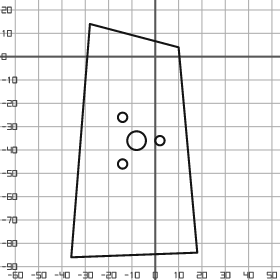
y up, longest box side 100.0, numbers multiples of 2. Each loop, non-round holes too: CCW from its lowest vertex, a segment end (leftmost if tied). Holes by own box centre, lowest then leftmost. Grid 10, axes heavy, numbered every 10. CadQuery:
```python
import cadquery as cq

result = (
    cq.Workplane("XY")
    .moveTo(-36.0, -86.0)
    .lineTo(18.0, -84.0)
    .lineTo(10.0, 4.0)
    .lineTo(-28.0, 14.0)
    .close()
    .moveTo(-14.0, -46.0)
    .circle(2.0)
    .moveTo(-8.0, -36.0)
    .circle(4.0)
    .moveTo(2.0, -36.0)
    .circle(2.0)
    .moveTo(-14.0, -26.0)
    .circle(2.0)
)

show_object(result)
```